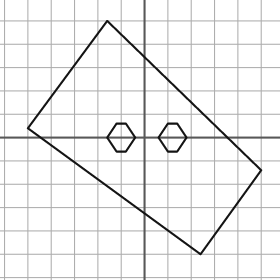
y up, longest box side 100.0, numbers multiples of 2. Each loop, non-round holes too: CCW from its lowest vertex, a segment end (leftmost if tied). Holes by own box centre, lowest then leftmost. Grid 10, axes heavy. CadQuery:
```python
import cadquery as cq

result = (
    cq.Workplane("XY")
    .moveTo(24.0, -50.0)
    .lineTo(50.0, -14.0)
    .lineTo(-16.0, 50.0)
    .lineTo(-50.0, 4.0)
    .close()
    .moveTo(-12.0, -6.0)
    .lineTo(-8.0, -6.0)
    .lineTo(-4.0, 0.0)
    .lineTo(-8.0, 6.0)
    .lineTo(-12.0, 6.0)
    .lineTo(-16.0, 0.0)
    .close()
    .moveTo(10.0, -6.0)
    .lineTo(14.0, -6.0)
    .lineTo(18.0, 0.0)
    .lineTo(14.0, 6.0)
    .lineTo(10.0, 6.0)
    .lineTo(6.0, 0.0)
    .close()
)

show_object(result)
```